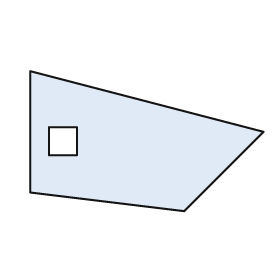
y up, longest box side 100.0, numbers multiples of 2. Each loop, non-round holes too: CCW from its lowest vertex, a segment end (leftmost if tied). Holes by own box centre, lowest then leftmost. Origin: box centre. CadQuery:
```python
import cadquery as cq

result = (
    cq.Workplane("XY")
    .moveTo(16.0, -30.0)
    .lineTo(50.0, 4.0)
    .lineTo(-50.0, 30.0)
    .lineTo(-50.0, -22.0)
    .close()
    .moveTo(-42.0, -6.0)
    .lineTo(-30.0, -6.0)
    .lineTo(-30.0, 6.0)
    .lineTo(-42.0, 6.0)
    .close()
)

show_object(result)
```